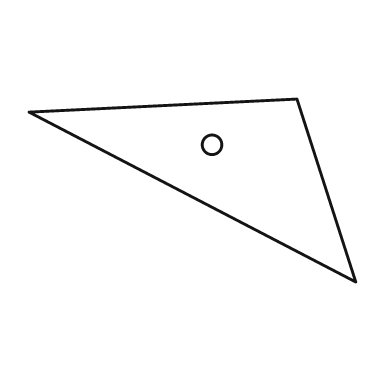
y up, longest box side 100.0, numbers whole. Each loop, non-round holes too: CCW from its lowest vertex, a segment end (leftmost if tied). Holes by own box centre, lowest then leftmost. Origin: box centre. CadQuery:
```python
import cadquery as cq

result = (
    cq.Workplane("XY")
    .moveTo(50.0, -28.0)
    .lineTo(32.0, 28.0)
    .lineTo(-50.0, 24.0)
    .close()
    .moveTo(6.0, 14.0)
    .circle(3.0)
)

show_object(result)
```